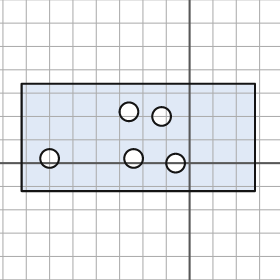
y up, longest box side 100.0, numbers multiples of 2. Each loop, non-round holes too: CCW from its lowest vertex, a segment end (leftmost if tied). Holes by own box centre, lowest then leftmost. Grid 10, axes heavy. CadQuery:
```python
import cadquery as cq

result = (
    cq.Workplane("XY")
    .moveTo(-72.0, -12.0)
    .lineTo(28.0, -12.0)
    .lineTo(28.0, 34.0)
    .lineTo(-72.0, 34.0)
    .close()
    .moveTo(-6.0, 0.0)
    .circle(4.0)
    .moveTo(-60.0, 2.0)
    .circle(4.0)
    .moveTo(-24.0, 2.0)
    .circle(4.0)
    .moveTo(-12.0, 20.0)
    .circle(4.0)
    .moveTo(-26.0, 22.0)
    .circle(4.0)
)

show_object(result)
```